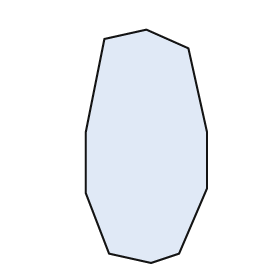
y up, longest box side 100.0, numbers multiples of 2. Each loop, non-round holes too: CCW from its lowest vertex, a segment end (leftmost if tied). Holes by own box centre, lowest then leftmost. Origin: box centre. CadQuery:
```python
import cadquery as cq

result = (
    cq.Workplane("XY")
    .moveTo(2.0, -50.0)
    .lineTo(14.0, -46.0)
    .lineTo(26.0, -18.0)
    .lineTo(26.0, 6.0)
    .lineTo(18.0, 42.0)
    .lineTo(0.0, 50.0)
    .lineTo(-18.0, 46.0)
    .lineTo(-26.0, 6.0)
    .lineTo(-26.0, -20.0)
    .lineTo(-16.0, -46.0)
    .close()
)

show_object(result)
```